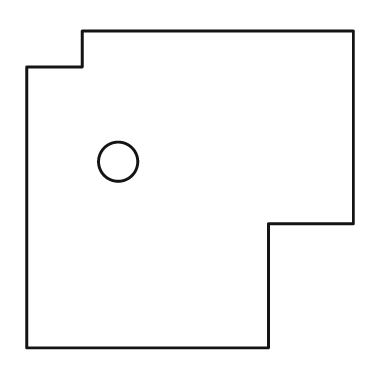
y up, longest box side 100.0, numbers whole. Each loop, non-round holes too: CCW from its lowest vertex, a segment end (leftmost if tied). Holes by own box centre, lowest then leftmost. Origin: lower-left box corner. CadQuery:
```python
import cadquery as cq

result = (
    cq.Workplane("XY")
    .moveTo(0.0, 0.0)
    .lineTo(74.0, 0.0)
    .lineTo(74.0, 38.0)
    .lineTo(100.0, 38.0)
    .lineTo(100.0, 97.0)
    .lineTo(17.0, 97.0)
    .lineTo(17.0, 86.0)
    .lineTo(0.0, 86.0)
    .close()
    .moveTo(28.0, 57.0)
    .circle(6.0)
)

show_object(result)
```